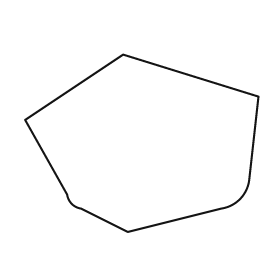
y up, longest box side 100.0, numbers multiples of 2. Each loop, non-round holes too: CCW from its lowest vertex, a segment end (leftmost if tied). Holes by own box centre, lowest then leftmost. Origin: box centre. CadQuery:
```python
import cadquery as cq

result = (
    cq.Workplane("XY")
    .moveTo(-6.0, -38.0)
    .lineTo(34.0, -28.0)
    .threePointArc((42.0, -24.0), (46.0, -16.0))
    .lineTo(50.0, 20.0)
    .lineTo(-8.0, 38.0)
    .lineTo(-50.0, 10.0)
    .lineTo(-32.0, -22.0)
    .threePointArc((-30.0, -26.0), (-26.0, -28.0))
    .close()
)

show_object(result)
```